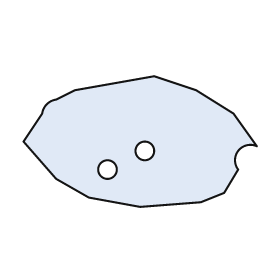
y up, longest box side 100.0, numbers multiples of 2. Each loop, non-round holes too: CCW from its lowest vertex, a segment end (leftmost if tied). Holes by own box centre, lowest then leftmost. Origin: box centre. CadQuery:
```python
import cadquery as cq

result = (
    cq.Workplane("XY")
    .moveTo(0.0, -28.0)
    .lineTo(26.0, -26.0)
    .lineTo(36.0, -22.0)
    .lineTo(42.0, -12.0)
    .threePointArc((42.0, -4.0), (50.0, -2.0))
    .lineTo(40.0, 12.0)
    .lineTo(24.0, 22.0)
    .lineTo(6.0, 28.0)
    .lineTo(-28.0, 22.0)
    .lineTo(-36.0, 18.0)
    .threePointArc((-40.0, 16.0), (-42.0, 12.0))
    .lineTo(-50.0, 0.0)
    .lineTo(-36.0, -16.0)
    .lineTo(-22.0, -24.0)
    .close()
    .moveTo(-14.0, -12.0)
    .circle(4.0)
    .moveTo(2.0, -4.0)
    .circle(4.0)
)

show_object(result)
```